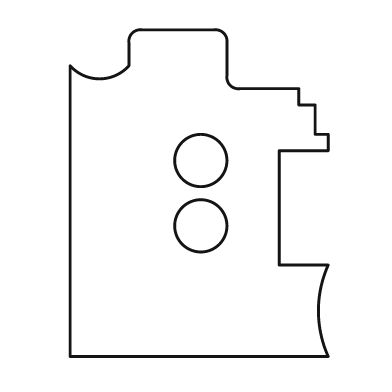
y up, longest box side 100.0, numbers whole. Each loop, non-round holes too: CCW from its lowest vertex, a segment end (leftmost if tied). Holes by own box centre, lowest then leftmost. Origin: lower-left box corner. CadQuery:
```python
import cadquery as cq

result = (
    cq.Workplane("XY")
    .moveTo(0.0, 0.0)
    .lineTo(79.0, 0.0)
    .threePointArc((76.0, 14.0), (79.0, 28.0))
    .lineTo(64.0, 28.0)
    .lineTo(64.0, 63.0)
    .lineTo(79.0, 63.0)
    .lineTo(79.0, 68.0)
    .lineTo(75.0, 68.0)
    .lineTo(75.0, 77.0)
    .lineTo(70.0, 77.0)
    .lineTo(70.0, 82.0)
    .lineTo(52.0, 82.0)
    .threePointArc((49.0, 83.0), (48.0, 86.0))
    .lineTo(48.0, 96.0)
    .threePointArc((47.0, 99.0), (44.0, 100.0))
    .lineTo(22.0, 100.0)
    .threePointArc((19.0, 99.0), (18.0, 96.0))
    .lineTo(18.0, 89.0)
    .threePointArc((9.0, 85.0), (0.0, 89.0))
    .close()
    .moveTo(40.0, 40.0)
    .circle(8.0)
    .moveTo(40.0, 60.0)
    .circle(8.0)
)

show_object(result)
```